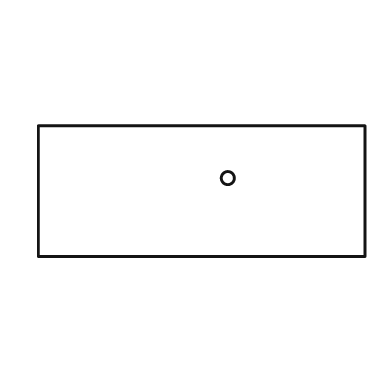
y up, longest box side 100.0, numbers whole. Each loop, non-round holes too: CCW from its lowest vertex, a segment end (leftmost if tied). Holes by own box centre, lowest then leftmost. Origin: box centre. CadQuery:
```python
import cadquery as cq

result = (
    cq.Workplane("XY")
    .moveTo(-50.0, -20.0)
    .lineTo(50.0, -20.0)
    .lineTo(50.0, 20.0)
    .lineTo(-50.0, 20.0)
    .close()
    .moveTo(8.0, 4.0)
    .circle(2.0)
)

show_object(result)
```